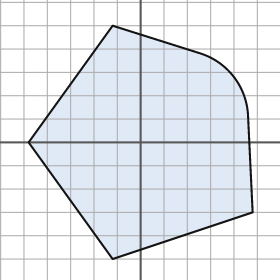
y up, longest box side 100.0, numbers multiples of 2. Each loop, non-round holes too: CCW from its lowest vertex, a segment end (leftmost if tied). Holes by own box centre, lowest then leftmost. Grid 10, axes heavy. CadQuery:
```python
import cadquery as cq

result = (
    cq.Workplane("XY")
    .moveTo(-12.0, -50.0)
    .lineTo(48.0, -30.0)
    .lineTo(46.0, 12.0)
    .threePointArc((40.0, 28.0), (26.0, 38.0))
    .lineTo(-12.0, 50.0)
    .lineTo(-48.0, 0.0)
    .close()
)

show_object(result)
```